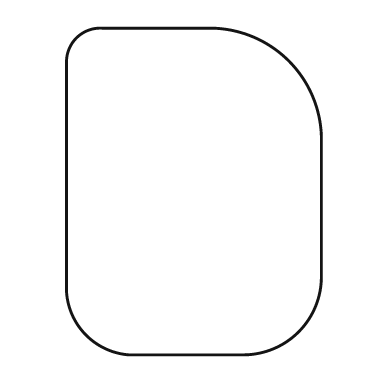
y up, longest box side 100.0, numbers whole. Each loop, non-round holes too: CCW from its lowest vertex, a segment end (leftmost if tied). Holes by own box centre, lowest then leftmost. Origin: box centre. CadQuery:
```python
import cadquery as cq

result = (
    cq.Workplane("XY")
    .moveTo(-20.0, -50.0)
    .lineTo(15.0, -50.0)
    .threePointArc((32.0, -43.0), (39.0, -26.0))
    .lineTo(39.0, 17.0)
    .threePointArc((29.0, 40.0), (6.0, 50.0))
    .lineTo(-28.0, 50.0)
    .threePointArc((-36.0, 47.0), (-39.0, 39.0))
    .lineTo(-39.0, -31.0)
    .threePointArc((-33.0, -44.0), (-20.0, -50.0))
    .close()
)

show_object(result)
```